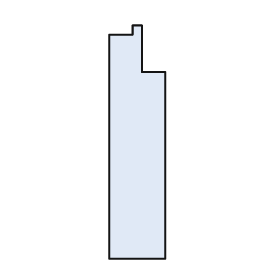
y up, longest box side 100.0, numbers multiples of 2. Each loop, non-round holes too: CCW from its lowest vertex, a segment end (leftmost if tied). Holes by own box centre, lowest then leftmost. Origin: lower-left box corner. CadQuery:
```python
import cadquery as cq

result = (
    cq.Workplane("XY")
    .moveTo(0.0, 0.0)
    .lineTo(24.0, 0.0)
    .lineTo(24.0, 80.0)
    .lineTo(14.0, 80.0)
    .lineTo(14.0, 100.0)
    .lineTo(10.0, 100.0)
    .lineTo(10.0, 96.0)
    .lineTo(0.0, 96.0)
    .close()
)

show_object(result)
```